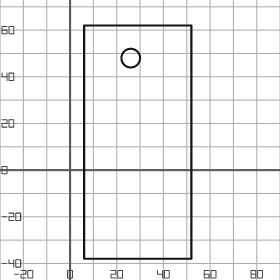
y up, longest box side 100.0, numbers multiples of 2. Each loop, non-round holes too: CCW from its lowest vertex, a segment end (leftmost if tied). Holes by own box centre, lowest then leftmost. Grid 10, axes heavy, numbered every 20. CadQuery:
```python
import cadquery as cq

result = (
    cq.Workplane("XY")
    .moveTo(6.0, -38.0)
    .lineTo(52.0, -38.0)
    .lineTo(52.0, 62.0)
    .lineTo(6.0, 62.0)
    .close()
    .moveTo(26.0, 48.0)
    .circle(4.0)
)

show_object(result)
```